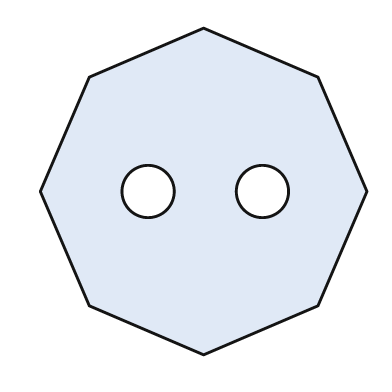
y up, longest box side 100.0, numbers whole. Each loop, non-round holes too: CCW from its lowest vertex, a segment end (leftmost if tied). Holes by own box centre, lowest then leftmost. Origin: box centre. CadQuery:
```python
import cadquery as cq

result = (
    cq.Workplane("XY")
    .moveTo(0.0, -50.0)
    .lineTo(35.0, -35.0)
    .lineTo(50.0, 0.0)
    .lineTo(35.0, 35.0)
    .lineTo(0.0, 50.0)
    .lineTo(-35.0, 35.0)
    .lineTo(-50.0, 0.0)
    .lineTo(-35.0, -35.0)
    .close()
    .moveTo(-17.0, 0.0)
    .circle(8.0)
    .moveTo(18.0, 0.0)
    .circle(8.0)
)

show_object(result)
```